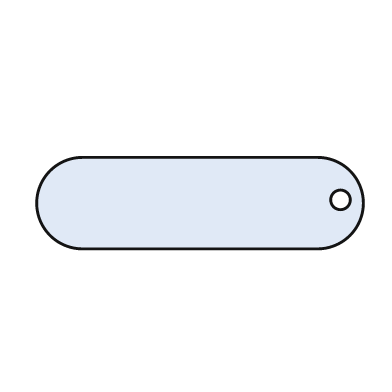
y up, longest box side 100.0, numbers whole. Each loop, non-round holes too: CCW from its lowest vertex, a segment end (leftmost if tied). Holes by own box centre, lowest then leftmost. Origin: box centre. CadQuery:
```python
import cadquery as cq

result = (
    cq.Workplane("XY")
    .moveTo(-36.0, -14.0)
    .lineTo(36.0, -14.0)
    .threePointArc((50.0, 0.0), (36.0, 14.0))
    .lineTo(-36.0, 14.0)
    .threePointArc((-50.0, 0.0), (-36.0, -14.0))
    .close()
    .moveTo(43.0, 1.0)
    .circle(3.0)
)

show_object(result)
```